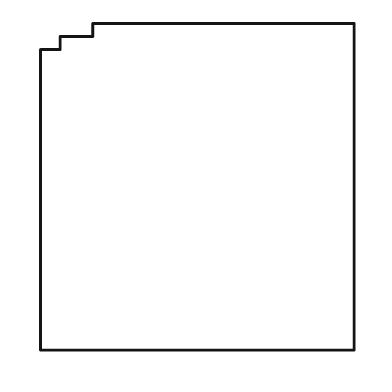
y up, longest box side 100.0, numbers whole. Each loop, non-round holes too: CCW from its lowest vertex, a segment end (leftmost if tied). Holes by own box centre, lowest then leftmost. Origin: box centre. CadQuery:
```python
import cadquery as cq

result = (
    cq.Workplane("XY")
    .moveTo(-48.0, -50.0)
    .lineTo(48.0, -50.0)
    .lineTo(48.0, 50.0)
    .lineTo(-32.0, 50.0)
    .lineTo(-32.0, 46.0)
    .lineTo(-42.0, 46.0)
    .lineTo(-42.0, 42.0)
    .lineTo(-48.0, 42.0)
    .close()
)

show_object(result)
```